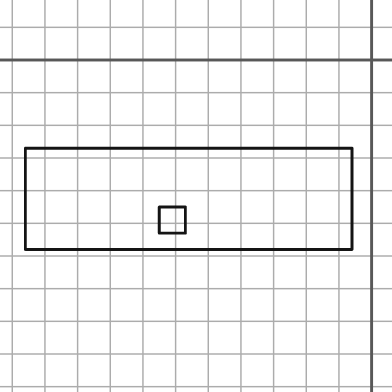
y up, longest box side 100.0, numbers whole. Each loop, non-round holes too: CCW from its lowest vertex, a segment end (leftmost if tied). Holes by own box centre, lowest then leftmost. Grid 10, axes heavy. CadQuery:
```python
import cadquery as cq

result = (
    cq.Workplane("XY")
    .moveTo(-106.0, -58.0)
    .lineTo(-6.0, -58.0)
    .lineTo(-6.0, -27.0)
    .lineTo(-106.0, -27.0)
    .close()
    .moveTo(-65.0, -53.0)
    .lineTo(-57.0, -53.0)
    .lineTo(-57.0, -45.0)
    .lineTo(-65.0, -45.0)
    .close()
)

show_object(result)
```